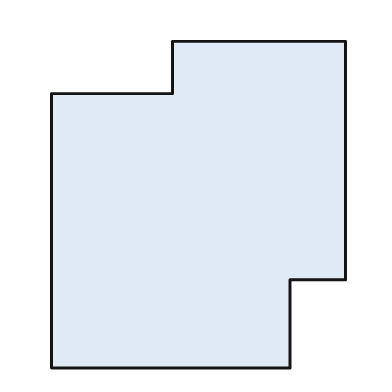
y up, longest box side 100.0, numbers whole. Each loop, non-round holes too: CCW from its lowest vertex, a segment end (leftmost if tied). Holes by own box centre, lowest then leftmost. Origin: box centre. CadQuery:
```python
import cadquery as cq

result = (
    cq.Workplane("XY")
    .moveTo(-45.0, -50.0)
    .lineTo(28.0, -50.0)
    .lineTo(28.0, -23.0)
    .lineTo(45.0, -23.0)
    .lineTo(45.0, 50.0)
    .lineTo(-8.0, 50.0)
    .lineTo(-8.0, 34.0)
    .lineTo(-45.0, 34.0)
    .close()
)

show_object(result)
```